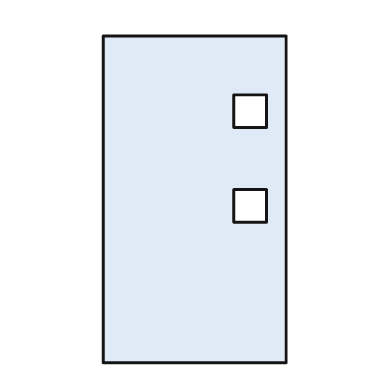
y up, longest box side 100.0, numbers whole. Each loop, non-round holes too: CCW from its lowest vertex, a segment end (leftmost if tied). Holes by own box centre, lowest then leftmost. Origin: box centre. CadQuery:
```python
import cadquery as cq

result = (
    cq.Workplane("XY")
    .moveTo(-28.0, -50.0)
    .lineTo(28.0, -50.0)
    .lineTo(28.0, 50.0)
    .lineTo(-28.0, 50.0)
    .close()
    .moveTo(12.0, -7.0)
    .lineTo(22.0, -7.0)
    .lineTo(22.0, 3.0)
    .lineTo(12.0, 3.0)
    .close()
    .moveTo(12.0, 22.0)
    .lineTo(22.0, 22.0)
    .lineTo(22.0, 32.0)
    .lineTo(12.0, 32.0)
    .close()
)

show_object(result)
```